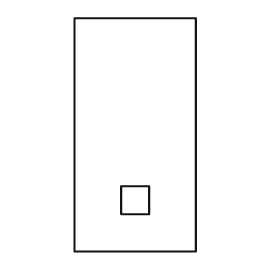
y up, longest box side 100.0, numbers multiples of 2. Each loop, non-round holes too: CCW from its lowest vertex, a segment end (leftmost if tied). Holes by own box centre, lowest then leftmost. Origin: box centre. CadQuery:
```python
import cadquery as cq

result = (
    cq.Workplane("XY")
    .moveTo(-26.0, -50.0)
    .lineTo(26.0, -50.0)
    .lineTo(26.0, 50.0)
    .lineTo(-26.0, 50.0)
    .close()
    .moveTo(-6.0, -34.0)
    .lineTo(6.0, -34.0)
    .lineTo(6.0, -22.0)
    .lineTo(-6.0, -22.0)
    .close()
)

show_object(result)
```